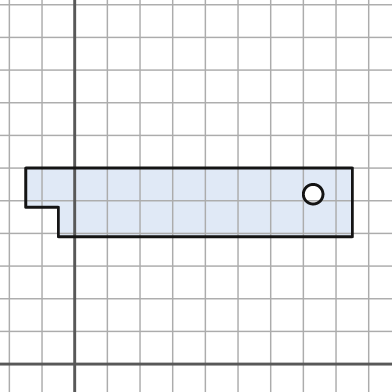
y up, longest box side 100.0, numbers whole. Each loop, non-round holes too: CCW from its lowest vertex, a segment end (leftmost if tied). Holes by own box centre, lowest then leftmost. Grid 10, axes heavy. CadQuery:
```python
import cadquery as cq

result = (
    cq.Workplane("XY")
    .moveTo(-5.0, 39.0)
    .lineTo(85.0, 39.0)
    .lineTo(85.0, 60.0)
    .lineTo(-15.0, 60.0)
    .lineTo(-15.0, 48.0)
    .lineTo(-5.0, 48.0)
    .close()
    .moveTo(73.0, 52.0)
    .circle(3.0)
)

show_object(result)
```